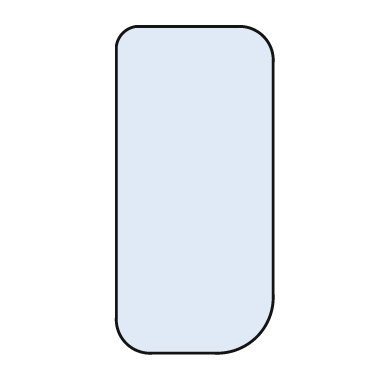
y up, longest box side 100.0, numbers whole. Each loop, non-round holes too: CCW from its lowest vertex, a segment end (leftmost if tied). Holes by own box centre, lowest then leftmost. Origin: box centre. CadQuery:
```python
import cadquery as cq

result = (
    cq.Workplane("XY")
    .moveTo(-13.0, -50.0)
    .lineTo(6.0, -50.0)
    .threePointArc((19.0, -45.0), (24.0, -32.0))
    .lineTo(24.0, 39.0)
    .threePointArc((21.0, 47.0), (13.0, 50.0))
    .lineTo(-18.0, 50.0)
    .threePointArc((-22.0, 48.0), (-24.0, 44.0))
    .lineTo(-24.0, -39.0)
    .threePointArc((-21.0, -47.0), (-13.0, -50.0))
    .close()
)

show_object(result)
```